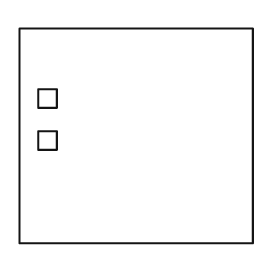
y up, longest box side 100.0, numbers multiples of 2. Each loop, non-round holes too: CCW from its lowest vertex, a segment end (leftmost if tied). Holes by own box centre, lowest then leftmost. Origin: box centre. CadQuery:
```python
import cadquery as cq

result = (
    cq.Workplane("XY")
    .moveTo(-50.0, -46.0)
    .lineTo(50.0, -46.0)
    .lineTo(50.0, 46.0)
    .lineTo(-50.0, 46.0)
    .close()
    .moveTo(-42.0, -6.0)
    .lineTo(-34.0, -6.0)
    .lineTo(-34.0, 2.0)
    .lineTo(-42.0, 2.0)
    .close()
    .moveTo(-42.0, 12.0)
    .lineTo(-34.0, 12.0)
    .lineTo(-34.0, 20.0)
    .lineTo(-42.0, 20.0)
    .close()
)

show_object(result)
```